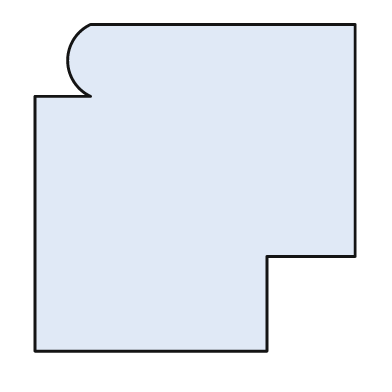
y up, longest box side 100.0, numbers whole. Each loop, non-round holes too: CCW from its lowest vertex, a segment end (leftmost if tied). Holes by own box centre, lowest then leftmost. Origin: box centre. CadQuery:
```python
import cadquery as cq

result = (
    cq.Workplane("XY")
    .moveTo(-49.0, -50.0)
    .lineTo(22.0, -50.0)
    .lineTo(22.0, -21.0)
    .lineTo(49.0, -21.0)
    .lineTo(49.0, 50.0)
    .lineTo(-32.0, 50.0)
    .threePointArc((-39.0, 39.0), (-32.0, 28.0))
    .lineTo(-49.0, 28.0)
    .close()
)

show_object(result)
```